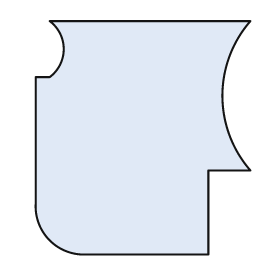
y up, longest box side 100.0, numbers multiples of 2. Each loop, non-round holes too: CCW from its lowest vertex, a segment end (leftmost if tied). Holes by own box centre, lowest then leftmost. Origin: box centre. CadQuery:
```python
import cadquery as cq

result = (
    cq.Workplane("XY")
    .moveTo(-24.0, -50.0)
    .lineTo(28.0, -50.0)
    .lineTo(28.0, -14.0)
    .lineTo(46.0, -14.0)
    .threePointArc((34.0, 18.0), (46.0, 50.0))
    .lineTo(-40.0, 50.0)
    .threePointArc((-34.0, 38.0), (-40.0, 26.0))
    .lineTo(-46.0, 26.0)
    .lineTo(-46.0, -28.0)
    .threePointArc((-40.0, -44.0), (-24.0, -50.0))
    .close()
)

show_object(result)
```